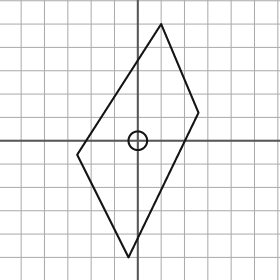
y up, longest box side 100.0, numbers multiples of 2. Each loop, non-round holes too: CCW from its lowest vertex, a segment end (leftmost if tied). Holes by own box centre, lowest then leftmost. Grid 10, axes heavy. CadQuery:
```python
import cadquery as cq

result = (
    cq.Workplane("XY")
    .moveTo(-4.0, -50.0)
    .lineTo(26.0, 12.0)
    .lineTo(10.0, 50.0)
    .lineTo(-26.0, -6.0)
    .close()
    .moveTo(0.0, 0.0)
    .circle(4.0)
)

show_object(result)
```